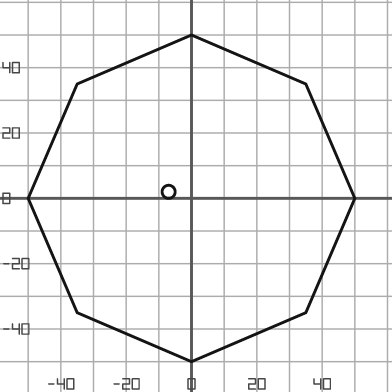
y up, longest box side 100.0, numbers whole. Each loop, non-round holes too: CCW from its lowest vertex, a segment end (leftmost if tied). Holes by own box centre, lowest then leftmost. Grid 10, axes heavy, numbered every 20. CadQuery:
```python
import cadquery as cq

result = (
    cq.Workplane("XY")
    .moveTo(0.0, -50.0)
    .lineTo(35.0, -35.0)
    .lineTo(50.0, 0.0)
    .lineTo(35.0, 35.0)
    .lineTo(0.0, 50.0)
    .lineTo(-35.0, 35.0)
    .lineTo(-50.0, 0.0)
    .lineTo(-35.0, -35.0)
    .close()
    .moveTo(-7.0, 2.0)
    .circle(2.0)
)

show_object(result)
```